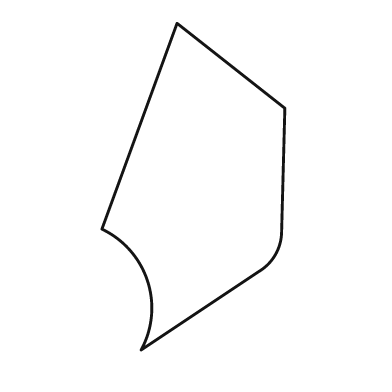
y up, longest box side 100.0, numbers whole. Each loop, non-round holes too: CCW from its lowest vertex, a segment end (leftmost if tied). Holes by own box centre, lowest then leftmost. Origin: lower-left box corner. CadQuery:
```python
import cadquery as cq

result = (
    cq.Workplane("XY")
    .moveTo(12.0, 0.0)
    .lineTo(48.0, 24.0)
    .threePointArc((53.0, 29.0), (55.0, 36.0))
    .lineTo(56.0, 74.0)
    .lineTo(23.0, 100.0)
    .lineTo(0.0, 37.0)
    .threePointArc((14.0, 21.0), (12.0, 0.0))
    .close()
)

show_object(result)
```